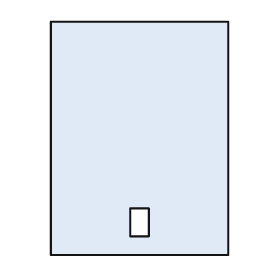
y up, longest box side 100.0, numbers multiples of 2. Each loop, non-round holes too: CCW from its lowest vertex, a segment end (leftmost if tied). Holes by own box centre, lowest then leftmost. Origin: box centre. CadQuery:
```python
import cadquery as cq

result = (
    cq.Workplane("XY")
    .moveTo(-38.0, -50.0)
    .lineTo(38.0, -50.0)
    .lineTo(38.0, 50.0)
    .lineTo(-38.0, 50.0)
    .close()
    .moveTo(-4.0, -42.0)
    .lineTo(4.0, -42.0)
    .lineTo(4.0, -30.0)
    .lineTo(-4.0, -30.0)
    .close()
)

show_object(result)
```